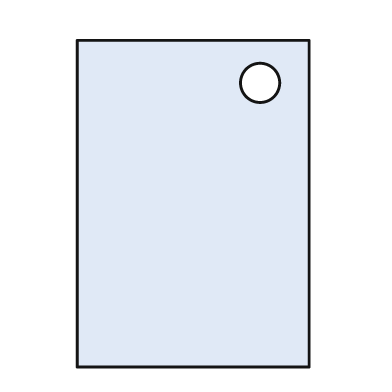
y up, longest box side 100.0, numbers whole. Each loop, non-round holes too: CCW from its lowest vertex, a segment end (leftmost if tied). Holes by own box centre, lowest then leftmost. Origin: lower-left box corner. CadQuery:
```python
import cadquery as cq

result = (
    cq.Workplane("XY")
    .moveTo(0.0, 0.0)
    .lineTo(71.0, 0.0)
    .lineTo(71.0, 100.0)
    .lineTo(0.0, 100.0)
    .close()
    .moveTo(56.0, 87.0)
    .circle(6.0)
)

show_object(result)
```